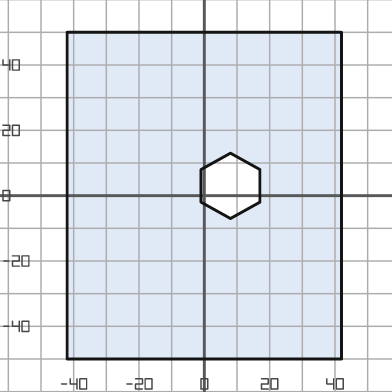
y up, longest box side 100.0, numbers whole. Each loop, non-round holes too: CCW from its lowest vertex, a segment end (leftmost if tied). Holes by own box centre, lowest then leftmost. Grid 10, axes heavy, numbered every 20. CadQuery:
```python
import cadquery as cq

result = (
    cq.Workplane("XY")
    .moveTo(-42.0, -50.0)
    .lineTo(42.0, -50.0)
    .lineTo(42.0, 50.0)
    .lineTo(-42.0, 50.0)
    .close()
    .moveTo(8.0, -7.0)
    .lineTo(17.0, -2.0)
    .lineTo(17.0, 8.0)
    .lineTo(8.0, 13.0)
    .lineTo(-1.0, 8.0)
    .lineTo(-1.0, -2.0)
    .close()
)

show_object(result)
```